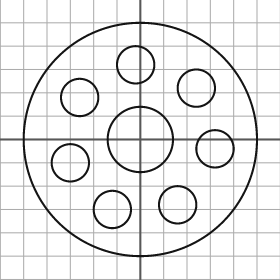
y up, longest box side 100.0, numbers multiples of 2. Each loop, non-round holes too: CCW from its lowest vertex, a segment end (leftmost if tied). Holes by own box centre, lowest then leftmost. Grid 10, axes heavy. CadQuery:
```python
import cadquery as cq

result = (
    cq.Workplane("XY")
    .moveTo(0.0, 0.0)
    .circle(50.0)
    .moveTo(-12.0, -30.0)
    .circle(8.0)
    .moveTo(16.0, -28.0)
    .circle(8.0)
    .moveTo(-30.0, -10.0)
    .circle(8.0)
    .moveTo(32.0, -4.0)
    .circle(8.0)
    .moveTo(0.0, 0.0)
    .circle(14.0)
    .moveTo(-26.0, 18.0)
    .circle(8.0)
    .moveTo(24.0, 22.0)
    .circle(8.0)
    .moveTo(-2.0, 32.0)
    .circle(8.0)
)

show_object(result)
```